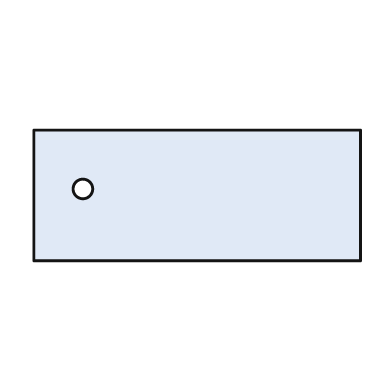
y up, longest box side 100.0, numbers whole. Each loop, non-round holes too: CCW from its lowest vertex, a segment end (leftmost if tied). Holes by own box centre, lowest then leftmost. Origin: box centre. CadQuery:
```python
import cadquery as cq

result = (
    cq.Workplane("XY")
    .moveTo(-50.0, -20.0)
    .lineTo(50.0, -20.0)
    .lineTo(50.0, 20.0)
    .lineTo(-50.0, 20.0)
    .close()
    .moveTo(-35.0, 2.0)
    .circle(3.0)
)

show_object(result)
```